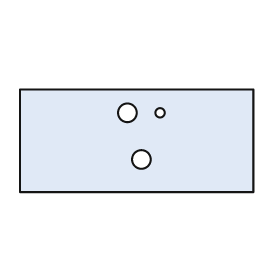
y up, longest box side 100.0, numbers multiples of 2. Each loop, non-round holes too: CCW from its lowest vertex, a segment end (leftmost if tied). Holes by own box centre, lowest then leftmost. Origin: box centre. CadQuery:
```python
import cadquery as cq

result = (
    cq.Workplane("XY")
    .moveTo(-50.0, -22.0)
    .lineTo(50.0, -22.0)
    .lineTo(50.0, 22.0)
    .lineTo(-50.0, 22.0)
    .close()
    .moveTo(2.0, -8.0)
    .circle(4.0)
    .moveTo(-4.0, 12.0)
    .circle(4.0)
    .moveTo(10.0, 12.0)
    .circle(2.0)
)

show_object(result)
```